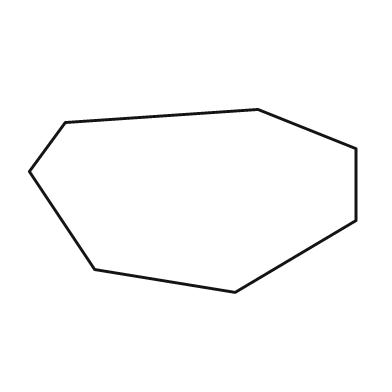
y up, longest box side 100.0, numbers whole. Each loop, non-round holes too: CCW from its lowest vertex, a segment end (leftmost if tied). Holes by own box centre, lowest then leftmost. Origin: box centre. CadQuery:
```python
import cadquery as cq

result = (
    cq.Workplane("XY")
    .moveTo(13.0, -28.0)
    .lineTo(50.0, -6.0)
    .lineTo(50.0, 16.0)
    .lineTo(20.0, 28.0)
    .lineTo(-39.0, 24.0)
    .lineTo(-50.0, 9.0)
    .lineTo(-30.0, -21.0)
    .close()
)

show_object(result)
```